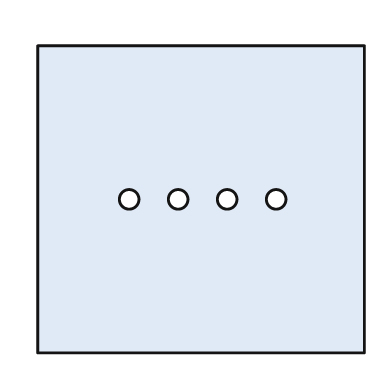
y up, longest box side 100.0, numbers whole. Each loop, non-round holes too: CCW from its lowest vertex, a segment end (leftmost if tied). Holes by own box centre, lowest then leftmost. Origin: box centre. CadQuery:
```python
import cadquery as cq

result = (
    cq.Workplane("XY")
    .moveTo(-50.0, -47.0)
    .lineTo(50.0, -47.0)
    .lineTo(50.0, 47.0)
    .lineTo(-50.0, 47.0)
    .close()
    .moveTo(-22.0, 0.0)
    .circle(3.0)
    .moveTo(-7.0, 0.0)
    .circle(3.0)
    .moveTo(8.0, 0.0)
    .circle(3.0)
    .moveTo(23.0, 0.0)
    .circle(3.0)
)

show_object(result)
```